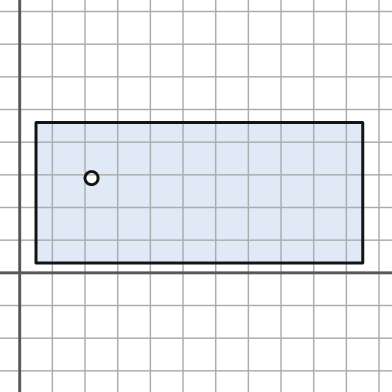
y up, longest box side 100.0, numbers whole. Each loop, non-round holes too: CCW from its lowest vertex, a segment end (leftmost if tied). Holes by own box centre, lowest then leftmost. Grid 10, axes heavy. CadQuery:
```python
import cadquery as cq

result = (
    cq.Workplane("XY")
    .moveTo(5.0, 3.0)
    .lineTo(105.0, 3.0)
    .lineTo(105.0, 46.0)
    .lineTo(5.0, 46.0)
    .close()
    .moveTo(22.0, 29.0)
    .circle(2.0)
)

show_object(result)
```